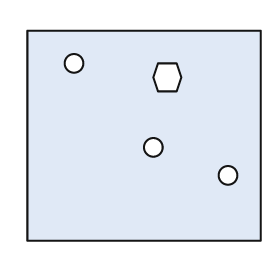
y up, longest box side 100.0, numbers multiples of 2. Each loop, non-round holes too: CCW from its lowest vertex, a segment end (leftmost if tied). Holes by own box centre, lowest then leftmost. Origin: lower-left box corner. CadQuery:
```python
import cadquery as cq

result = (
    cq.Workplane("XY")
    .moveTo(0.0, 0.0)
    .lineTo(100.0, 0.0)
    .lineTo(100.0, 90.0)
    .lineTo(0.0, 90.0)
    .close()
    .moveTo(86.0, 28.0)
    .circle(4.0)
    .moveTo(54.0, 40.0)
    .circle(4.0)
    .moveTo(56.0, 64.0)
    .lineTo(64.0, 64.0)
    .lineTo(66.0, 70.0)
    .lineTo(64.0, 76.0)
    .lineTo(56.0, 76.0)
    .lineTo(54.0, 70.0)
    .close()
    .moveTo(20.0, 76.0)
    .circle(4.0)
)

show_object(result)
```